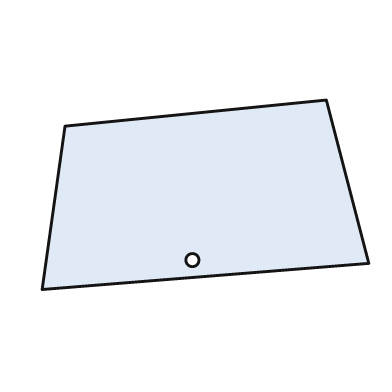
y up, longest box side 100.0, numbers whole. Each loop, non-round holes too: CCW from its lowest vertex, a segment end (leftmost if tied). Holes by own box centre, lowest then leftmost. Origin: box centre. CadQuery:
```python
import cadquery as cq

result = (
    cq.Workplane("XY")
    .moveTo(-50.0, -29.0)
    .lineTo(50.0, -21.0)
    .lineTo(37.0, 29.0)
    .lineTo(-43.0, 21.0)
    .close()
    .moveTo(-4.0, -20.0)
    .circle(2.0)
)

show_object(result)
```